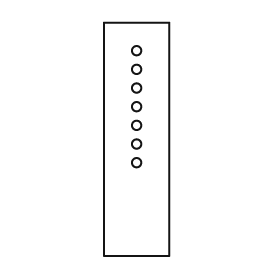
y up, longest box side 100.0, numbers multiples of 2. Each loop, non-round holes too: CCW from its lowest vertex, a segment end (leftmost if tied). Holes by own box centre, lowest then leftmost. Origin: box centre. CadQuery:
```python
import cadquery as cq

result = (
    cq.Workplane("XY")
    .moveTo(-14.0, -50.0)
    .lineTo(14.0, -50.0)
    .lineTo(14.0, 50.0)
    .lineTo(-14.0, 50.0)
    .close()
    .moveTo(0.0, -10.0)
    .circle(2.0)
    .moveTo(0.0, -2.0)
    .circle(2.0)
    .moveTo(0.0, 6.0)
    .circle(2.0)
    .moveTo(0.0, 14.0)
    .circle(2.0)
    .moveTo(0.0, 22.0)
    .circle(2.0)
    .moveTo(0.0, 30.0)
    .circle(2.0)
    .moveTo(0.0, 38.0)
    .circle(2.0)
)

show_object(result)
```